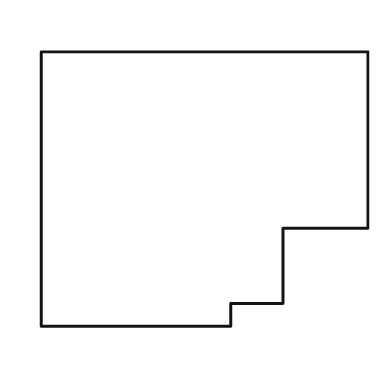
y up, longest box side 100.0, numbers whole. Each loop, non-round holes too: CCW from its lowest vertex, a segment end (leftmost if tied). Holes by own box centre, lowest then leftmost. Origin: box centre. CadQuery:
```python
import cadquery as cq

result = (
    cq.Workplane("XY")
    .moveTo(-50.0, -42.0)
    .lineTo(8.0, -42.0)
    .lineTo(8.0, -35.0)
    .lineTo(24.0, -35.0)
    .lineTo(24.0, -12.0)
    .lineTo(50.0, -12.0)
    .lineTo(50.0, 42.0)
    .lineTo(-50.0, 42.0)
    .close()
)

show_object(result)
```